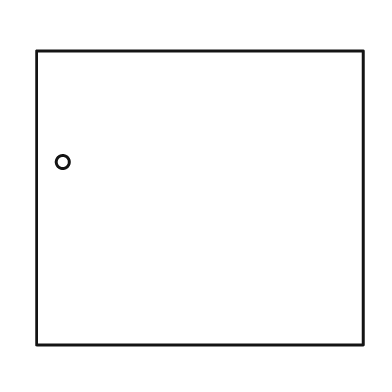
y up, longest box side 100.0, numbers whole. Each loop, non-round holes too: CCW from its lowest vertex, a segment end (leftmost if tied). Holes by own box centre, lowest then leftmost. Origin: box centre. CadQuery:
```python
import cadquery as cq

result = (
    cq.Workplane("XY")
    .moveTo(-50.0, -45.0)
    .lineTo(50.0, -45.0)
    .lineTo(50.0, 45.0)
    .lineTo(-50.0, 45.0)
    .close()
    .moveTo(-42.0, 11.0)
    .circle(2.0)
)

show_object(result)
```